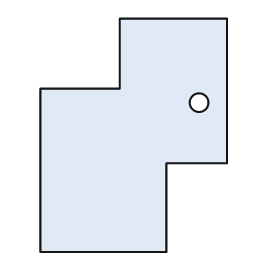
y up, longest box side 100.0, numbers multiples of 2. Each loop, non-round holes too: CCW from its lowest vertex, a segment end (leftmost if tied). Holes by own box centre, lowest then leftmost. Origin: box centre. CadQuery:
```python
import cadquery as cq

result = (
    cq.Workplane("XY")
    .moveTo(-40.0, -50.0)
    .lineTo(14.0, -50.0)
    .lineTo(14.0, -12.0)
    .lineTo(40.0, -12.0)
    .lineTo(40.0, 50.0)
    .lineTo(-6.0, 50.0)
    .lineTo(-6.0, 20.0)
    .lineTo(-40.0, 20.0)
    .close()
    .moveTo(28.0, 14.0)
    .circle(4.0)
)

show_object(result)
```